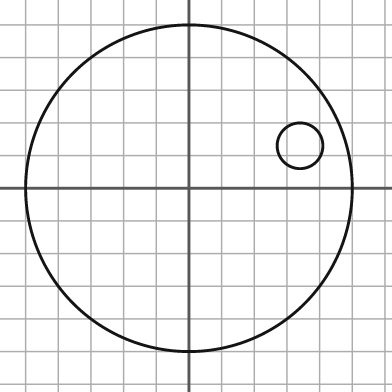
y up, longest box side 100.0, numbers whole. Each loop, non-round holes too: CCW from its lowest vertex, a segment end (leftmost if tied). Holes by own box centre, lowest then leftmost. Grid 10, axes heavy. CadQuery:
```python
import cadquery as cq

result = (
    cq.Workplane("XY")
    .moveTo(0.0, 0.0)
    .circle(50.0)
    .moveTo(34.0, 13.0)
    .circle(7.0)
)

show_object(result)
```